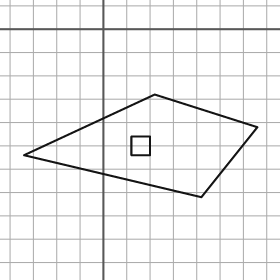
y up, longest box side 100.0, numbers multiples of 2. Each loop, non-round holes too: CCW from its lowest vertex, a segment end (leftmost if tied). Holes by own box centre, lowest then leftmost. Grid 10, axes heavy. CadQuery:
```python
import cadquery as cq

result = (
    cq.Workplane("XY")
    .moveTo(42.0, -72.0)
    .lineTo(66.0, -42.0)
    .lineTo(22.0, -28.0)
    .lineTo(-34.0, -54.0)
    .close()
    .moveTo(12.0, -54.0)
    .lineTo(20.0, -54.0)
    .lineTo(20.0, -46.0)
    .lineTo(12.0, -46.0)
    .close()
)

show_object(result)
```